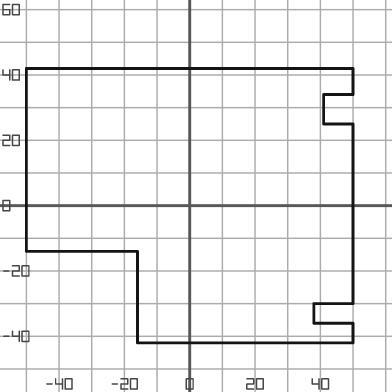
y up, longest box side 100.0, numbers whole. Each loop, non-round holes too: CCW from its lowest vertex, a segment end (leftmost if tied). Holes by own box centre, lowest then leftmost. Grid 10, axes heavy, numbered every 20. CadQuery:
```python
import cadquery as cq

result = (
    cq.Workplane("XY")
    .moveTo(-16.0, -42.0)
    .lineTo(50.0, -42.0)
    .lineTo(50.0, -36.0)
    .lineTo(38.0, -36.0)
    .lineTo(38.0, -30.0)
    .lineTo(50.0, -30.0)
    .lineTo(50.0, 25.0)
    .lineTo(41.0, 25.0)
    .lineTo(41.0, 34.0)
    .lineTo(50.0, 34.0)
    .lineTo(50.0, 42.0)
    .lineTo(-50.0, 42.0)
    .lineTo(-50.0, -14.0)
    .lineTo(-16.0, -14.0)
    .close()
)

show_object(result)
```